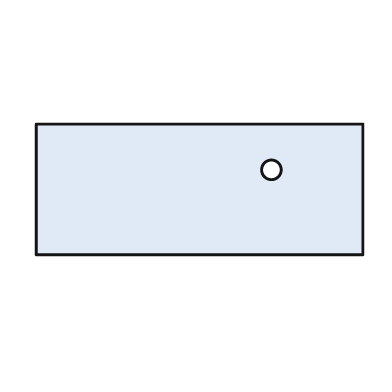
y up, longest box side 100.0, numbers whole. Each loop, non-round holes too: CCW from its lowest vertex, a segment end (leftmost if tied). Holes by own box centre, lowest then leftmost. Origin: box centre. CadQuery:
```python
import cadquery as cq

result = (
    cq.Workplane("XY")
    .moveTo(-50.0, -20.0)
    .lineTo(50.0, -20.0)
    .lineTo(50.0, 20.0)
    .lineTo(-50.0, 20.0)
    .close()
    .moveTo(22.0, 6.0)
    .circle(3.0)
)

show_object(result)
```